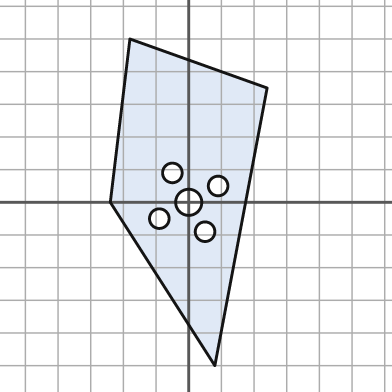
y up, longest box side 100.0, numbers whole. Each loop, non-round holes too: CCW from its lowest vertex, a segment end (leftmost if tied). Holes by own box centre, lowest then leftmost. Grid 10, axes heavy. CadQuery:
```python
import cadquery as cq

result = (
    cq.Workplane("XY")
    .moveTo(8.0, -50.0)
    .lineTo(24.0, 35.0)
    .lineTo(-18.0, 50.0)
    .lineTo(-24.0, 0.0)
    .close()
    .moveTo(5.0, -9.0)
    .circle(3.0)
    .moveTo(-9.0, -5.0)
    .circle(3.0)
    .moveTo(0.0, 0.0)
    .circle(4.0)
    .moveTo(9.0, 5.0)
    .circle(3.0)
    .moveTo(-5.0, 9.0)
    .circle(3.0)
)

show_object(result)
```